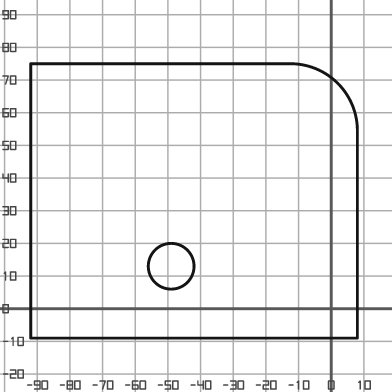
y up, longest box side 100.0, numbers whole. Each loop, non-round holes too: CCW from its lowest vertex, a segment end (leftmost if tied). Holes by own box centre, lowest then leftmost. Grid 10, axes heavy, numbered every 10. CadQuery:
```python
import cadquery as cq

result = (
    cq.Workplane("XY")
    .moveTo(-92.0, -9.0)
    .lineTo(8.0, -9.0)
    .lineTo(8.0, 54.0)
    .threePointArc((2.0, 69.0), (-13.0, 75.0))
    .lineTo(-92.0, 75.0)
    .close()
    .moveTo(-49.0, 13.0)
    .circle(7.0)
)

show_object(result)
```